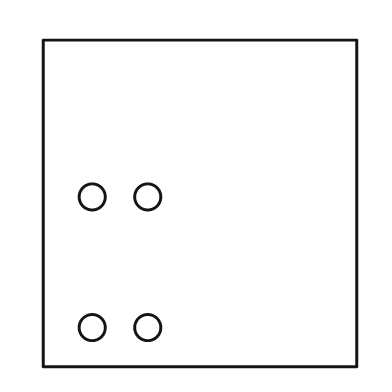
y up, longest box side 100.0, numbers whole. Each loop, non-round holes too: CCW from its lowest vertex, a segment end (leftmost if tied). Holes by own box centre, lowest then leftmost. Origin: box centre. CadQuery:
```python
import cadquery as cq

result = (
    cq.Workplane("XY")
    .moveTo(-48.0, -50.0)
    .lineTo(48.0, -50.0)
    .lineTo(48.0, 50.0)
    .lineTo(-48.0, 50.0)
    .close()
    .moveTo(-33.0, -38.0)
    .circle(4.0)
    .moveTo(-16.0, -38.0)
    .circle(4.0)
    .moveTo(-33.0, 2.0)
    .circle(4.0)
    .moveTo(-16.0, 2.0)
    .circle(4.0)
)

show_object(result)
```